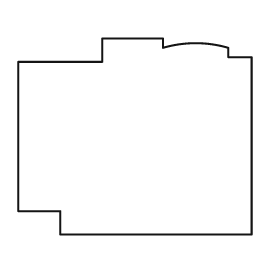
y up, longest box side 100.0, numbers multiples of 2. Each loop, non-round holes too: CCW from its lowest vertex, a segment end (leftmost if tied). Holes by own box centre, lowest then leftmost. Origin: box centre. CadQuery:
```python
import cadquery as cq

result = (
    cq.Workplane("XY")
    .moveTo(-32.0, -42.0)
    .lineTo(50.0, -42.0)
    .lineTo(50.0, 34.0)
    .lineTo(40.0, 34.0)
    .lineTo(40.0, 38.0)
    .threePointArc((26.0, 40.0), (12.0, 38.0))
    .lineTo(12.0, 42.0)
    .lineTo(-14.0, 42.0)
    .lineTo(-14.0, 32.0)
    .lineTo(-50.0, 32.0)
    .lineTo(-50.0, -32.0)
    .lineTo(-32.0, -32.0)
    .close()
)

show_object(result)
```